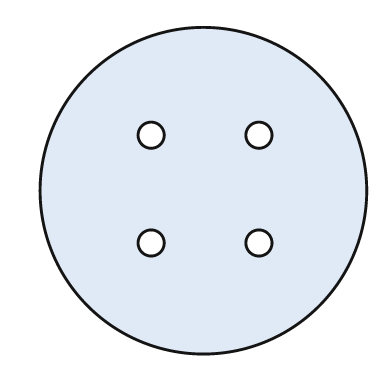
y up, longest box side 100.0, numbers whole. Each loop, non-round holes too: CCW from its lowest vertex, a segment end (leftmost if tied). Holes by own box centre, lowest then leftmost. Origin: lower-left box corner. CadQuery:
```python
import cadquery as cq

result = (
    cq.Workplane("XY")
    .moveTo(50.0, 50.0)
    .circle(50.0)
    .moveTo(34.0, 34.0)
    .circle(4.0)
    .moveTo(67.0, 34.0)
    .circle(4.0)
    .moveTo(34.0, 67.0)
    .circle(4.0)
    .moveTo(67.0, 67.0)
    .circle(4.0)
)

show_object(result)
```